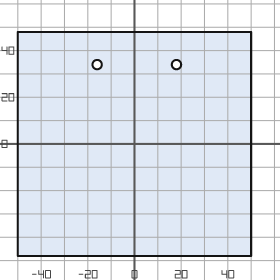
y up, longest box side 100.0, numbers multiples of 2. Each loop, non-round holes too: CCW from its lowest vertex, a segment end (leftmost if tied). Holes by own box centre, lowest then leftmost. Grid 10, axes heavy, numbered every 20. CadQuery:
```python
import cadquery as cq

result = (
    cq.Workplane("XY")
    .moveTo(-50.0, -48.0)
    .lineTo(50.0, -48.0)
    .lineTo(50.0, 48.0)
    .lineTo(-50.0, 48.0)
    .close()
    .moveTo(-16.0, 34.0)
    .circle(2.0)
    .moveTo(18.0, 34.0)
    .circle(2.0)
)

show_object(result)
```